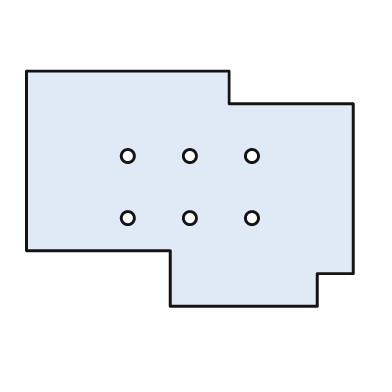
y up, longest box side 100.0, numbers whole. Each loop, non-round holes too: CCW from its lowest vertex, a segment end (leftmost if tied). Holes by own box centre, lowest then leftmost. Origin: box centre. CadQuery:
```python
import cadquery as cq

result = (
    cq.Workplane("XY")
    .moveTo(-6.0, -36.0)
    .lineTo(39.0, -36.0)
    .lineTo(39.0, -26.0)
    .lineTo(50.0, -26.0)
    .lineTo(50.0, 26.0)
    .lineTo(12.0, 26.0)
    .lineTo(12.0, 36.0)
    .lineTo(-50.0, 36.0)
    .lineTo(-50.0, -19.0)
    .lineTo(-6.0, -19.0)
    .close()
    .moveTo(-19.0, -9.0)
    .circle(2.0)
    .moveTo(0.0, -9.0)
    .circle(2.0)
    .moveTo(19.0, -9.0)
    .circle(2.0)
    .moveTo(-19.0, 10.0)
    .circle(2.0)
    .moveTo(0.0, 10.0)
    .circle(2.0)
    .moveTo(19.0, 10.0)
    .circle(2.0)
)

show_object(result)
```